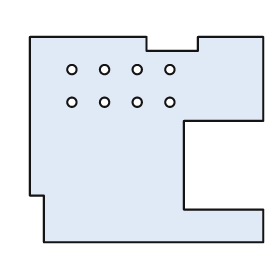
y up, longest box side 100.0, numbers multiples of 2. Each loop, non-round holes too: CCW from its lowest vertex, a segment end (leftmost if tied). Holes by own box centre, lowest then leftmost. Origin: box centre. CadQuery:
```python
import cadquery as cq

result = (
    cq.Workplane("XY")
    .moveTo(-44.0, -44.0)
    .lineTo(50.0, -44.0)
    .lineTo(50.0, -30.0)
    .lineTo(16.0, -30.0)
    .lineTo(16.0, 8.0)
    .lineTo(50.0, 8.0)
    .lineTo(50.0, 44.0)
    .lineTo(22.0, 44.0)
    .lineTo(22.0, 38.0)
    .lineTo(0.0, 38.0)
    .lineTo(0.0, 44.0)
    .lineTo(-50.0, 44.0)
    .lineTo(-50.0, -24.0)
    .lineTo(-44.0, -24.0)
    .close()
    .moveTo(-32.0, 16.0)
    .circle(2.0)
    .moveTo(-18.0, 16.0)
    .circle(2.0)
    .moveTo(-4.0, 16.0)
    .circle(2.0)
    .moveTo(10.0, 16.0)
    .circle(2.0)
    .moveTo(-32.0, 30.0)
    .circle(2.0)
    .moveTo(-18.0, 30.0)
    .circle(2.0)
    .moveTo(-4.0, 30.0)
    .circle(2.0)
    .moveTo(10.0, 30.0)
    .circle(2.0)
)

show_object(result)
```